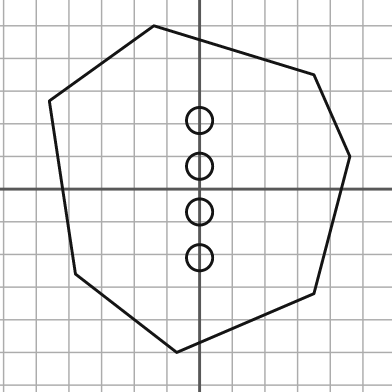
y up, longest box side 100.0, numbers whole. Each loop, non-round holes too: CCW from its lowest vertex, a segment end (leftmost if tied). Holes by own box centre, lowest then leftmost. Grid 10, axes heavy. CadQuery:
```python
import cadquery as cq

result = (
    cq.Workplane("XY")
    .moveTo(-7.0, -50.0)
    .lineTo(35.0, -32.0)
    .lineTo(46.0, 10.0)
    .lineTo(35.0, 35.0)
    .lineTo(-14.0, 50.0)
    .lineTo(-46.0, 27.0)
    .lineTo(-38.0, -26.0)
    .close()
    .moveTo(0.0, -21.0)
    .circle(4.0)
    .moveTo(0.0, -7.0)
    .circle(4.0)
    .moveTo(0.0, 7.0)
    .circle(4.0)
    .moveTo(0.0, 21.0)
    .circle(4.0)
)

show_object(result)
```